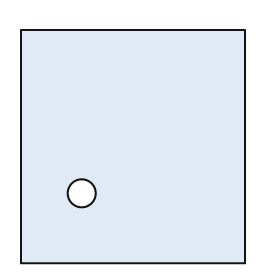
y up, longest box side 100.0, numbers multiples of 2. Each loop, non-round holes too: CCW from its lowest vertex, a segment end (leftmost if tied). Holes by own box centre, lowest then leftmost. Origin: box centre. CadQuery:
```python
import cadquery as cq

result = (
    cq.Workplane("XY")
    .moveTo(-48.0, -50.0)
    .lineTo(48.0, -50.0)
    .lineTo(48.0, 50.0)
    .lineTo(-48.0, 50.0)
    .close()
    .moveTo(-22.0, -20.0)
    .circle(6.0)
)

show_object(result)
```